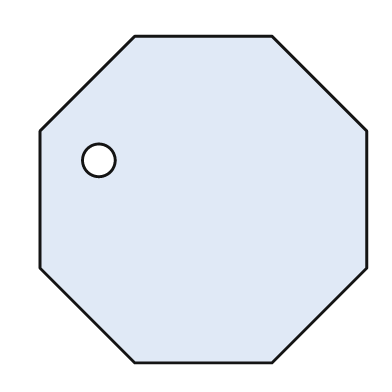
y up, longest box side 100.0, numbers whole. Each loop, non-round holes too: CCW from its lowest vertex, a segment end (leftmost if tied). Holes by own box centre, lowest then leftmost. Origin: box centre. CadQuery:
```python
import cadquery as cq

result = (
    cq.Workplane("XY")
    .moveTo(-21.0, -50.0)
    .lineTo(21.0, -50.0)
    .lineTo(50.0, -21.0)
    .lineTo(50.0, 21.0)
    .lineTo(21.0, 50.0)
    .lineTo(-21.0, 50.0)
    .lineTo(-50.0, 21.0)
    .lineTo(-50.0, -21.0)
    .close()
    .moveTo(-32.0, 12.0)
    .circle(5.0)
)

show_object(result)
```